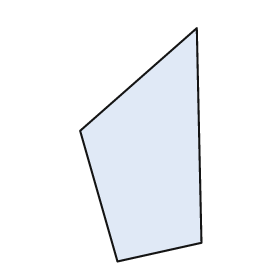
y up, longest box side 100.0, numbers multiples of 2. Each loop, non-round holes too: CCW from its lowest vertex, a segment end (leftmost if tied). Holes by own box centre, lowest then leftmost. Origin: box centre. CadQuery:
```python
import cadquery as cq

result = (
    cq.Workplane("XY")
    .moveTo(-10.0, -50.0)
    .lineTo(26.0, -42.0)
    .lineTo(24.0, 50.0)
    .lineTo(-26.0, 6.0)
    .close()
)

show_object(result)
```